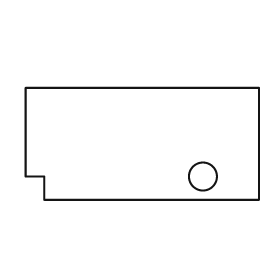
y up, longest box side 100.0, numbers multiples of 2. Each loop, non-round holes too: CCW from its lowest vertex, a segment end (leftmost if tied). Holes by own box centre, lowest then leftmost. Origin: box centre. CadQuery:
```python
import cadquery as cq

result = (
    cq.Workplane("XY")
    .moveTo(-42.0, -24.0)
    .lineTo(50.0, -24.0)
    .lineTo(50.0, 24.0)
    .lineTo(-50.0, 24.0)
    .lineTo(-50.0, -14.0)
    .lineTo(-42.0, -14.0)
    .close()
    .moveTo(26.0, -14.0)
    .circle(6.0)
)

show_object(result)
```